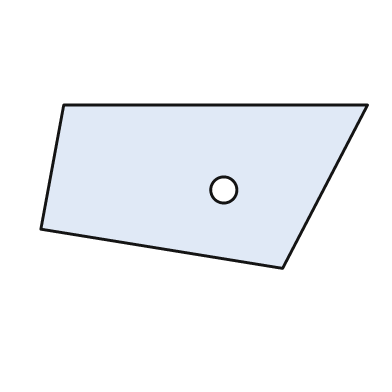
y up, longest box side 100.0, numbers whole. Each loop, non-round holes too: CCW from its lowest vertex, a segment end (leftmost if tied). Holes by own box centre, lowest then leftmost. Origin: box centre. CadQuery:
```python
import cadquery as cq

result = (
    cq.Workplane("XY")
    .moveTo(24.0, -25.0)
    .lineTo(50.0, 25.0)
    .lineTo(-43.0, 25.0)
    .lineTo(-50.0, -13.0)
    .close()
    .moveTo(6.0, -1.0)
    .circle(4.0)
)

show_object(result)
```